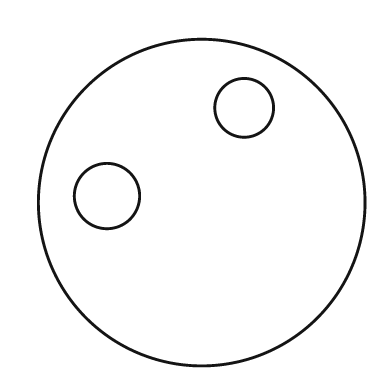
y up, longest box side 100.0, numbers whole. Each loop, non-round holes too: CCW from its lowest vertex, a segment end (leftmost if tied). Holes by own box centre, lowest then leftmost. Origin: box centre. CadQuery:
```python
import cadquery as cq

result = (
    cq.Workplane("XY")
    .moveTo(0.0, 0.0)
    .circle(50.0)
    .moveTo(-29.0, 2.0)
    .circle(10.0)
    .moveTo(13.0, 29.0)
    .circle(9.0)
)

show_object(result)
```